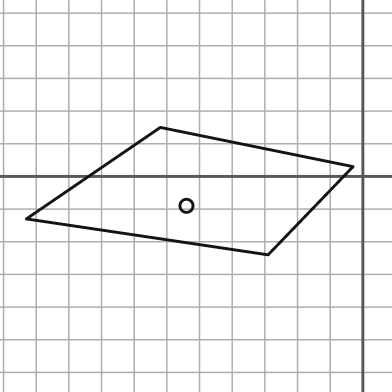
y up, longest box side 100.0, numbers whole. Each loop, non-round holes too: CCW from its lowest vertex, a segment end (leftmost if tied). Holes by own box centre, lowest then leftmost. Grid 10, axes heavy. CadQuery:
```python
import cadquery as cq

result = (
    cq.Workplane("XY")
    .moveTo(-29.0, -24.0)
    .lineTo(-3.0, 3.0)
    .lineTo(-62.0, 15.0)
    .lineTo(-103.0, -13.0)
    .close()
    .moveTo(-54.0, -9.0)
    .circle(2.0)
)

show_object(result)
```